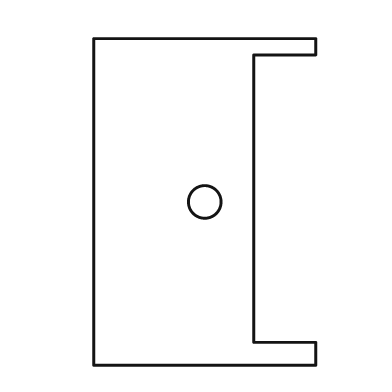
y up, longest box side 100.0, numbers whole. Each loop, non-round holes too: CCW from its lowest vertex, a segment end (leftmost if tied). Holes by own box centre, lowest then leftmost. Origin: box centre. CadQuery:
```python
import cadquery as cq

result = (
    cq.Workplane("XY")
    .moveTo(-34.0, -50.0)
    .lineTo(34.0, -50.0)
    .lineTo(34.0, -43.0)
    .lineTo(15.0, -43.0)
    .lineTo(15.0, 45.0)
    .lineTo(34.0, 45.0)
    .lineTo(34.0, 50.0)
    .lineTo(-34.0, 50.0)
    .close()
    .moveTo(0.0, 0.0)
    .circle(5.0)
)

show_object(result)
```